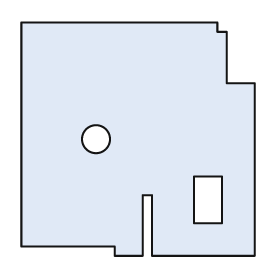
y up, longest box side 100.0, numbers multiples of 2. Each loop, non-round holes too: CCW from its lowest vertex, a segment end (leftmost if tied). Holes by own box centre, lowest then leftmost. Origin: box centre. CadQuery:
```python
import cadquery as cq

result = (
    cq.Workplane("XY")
    .moveTo(-10.0, -50.0)
    .lineTo(2.0, -50.0)
    .lineTo(2.0, -24.0)
    .lineTo(6.0, -24.0)
    .lineTo(6.0, -50.0)
    .lineTo(50.0, -50.0)
    .lineTo(50.0, 24.0)
    .lineTo(38.0, 24.0)
    .lineTo(38.0, 46.0)
    .lineTo(34.0, 46.0)
    .lineTo(34.0, 50.0)
    .lineTo(-50.0, 50.0)
    .lineTo(-50.0, -46.0)
    .lineTo(-10.0, -46.0)
    .close()
    .moveTo(24.0, -36.0)
    .lineTo(36.0, -36.0)
    .lineTo(36.0, -16.0)
    .lineTo(24.0, -16.0)
    .close()
    .moveTo(-18.0, 0.0)
    .circle(6.0)
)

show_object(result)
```